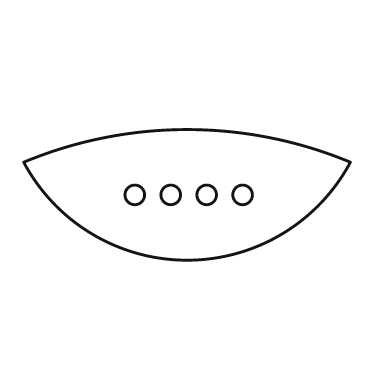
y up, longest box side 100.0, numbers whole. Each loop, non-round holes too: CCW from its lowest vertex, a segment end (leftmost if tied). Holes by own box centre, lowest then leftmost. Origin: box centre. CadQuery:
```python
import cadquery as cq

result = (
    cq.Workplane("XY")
    .moveTo(-50.0, 10.0)
    .threePointArc((0.0, -20.0), (50.0, 10.0))
    .threePointArc((0.0, 20.0), (-50.0, 10.0))
    .close()
    .moveTo(-16.0, 0.0)
    .circle(3.0)
    .moveTo(-5.0, 0.0)
    .circle(3.0)
    .moveTo(6.0, 0.0)
    .circle(3.0)
    .moveTo(17.0, 0.0)
    .circle(3.0)
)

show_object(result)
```